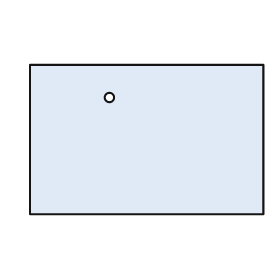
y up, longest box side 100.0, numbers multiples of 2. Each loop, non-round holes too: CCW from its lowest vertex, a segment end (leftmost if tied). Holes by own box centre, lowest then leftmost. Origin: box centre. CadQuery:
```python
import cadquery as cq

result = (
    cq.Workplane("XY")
    .moveTo(-50.0, -32.0)
    .lineTo(50.0, -32.0)
    .lineTo(50.0, 32.0)
    .lineTo(-50.0, 32.0)
    .close()
    .moveTo(-16.0, 18.0)
    .circle(2.0)
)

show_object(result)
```